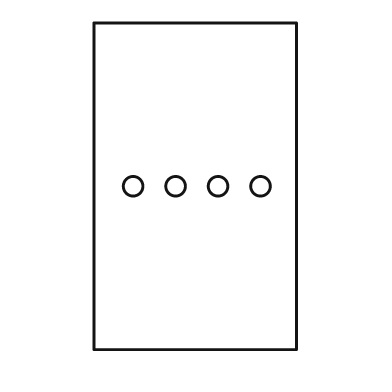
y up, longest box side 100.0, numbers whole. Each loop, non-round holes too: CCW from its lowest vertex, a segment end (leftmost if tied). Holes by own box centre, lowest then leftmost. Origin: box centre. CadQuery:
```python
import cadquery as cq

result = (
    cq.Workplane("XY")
    .moveTo(-31.0, -50.0)
    .lineTo(31.0, -50.0)
    .lineTo(31.0, 50.0)
    .lineTo(-31.0, 50.0)
    .close()
    .moveTo(-19.0, 0.0)
    .circle(3.0)
    .moveTo(-6.0, 0.0)
    .circle(3.0)
    .moveTo(7.0, 0.0)
    .circle(3.0)
    .moveTo(20.0, 0.0)
    .circle(3.0)
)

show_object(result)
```